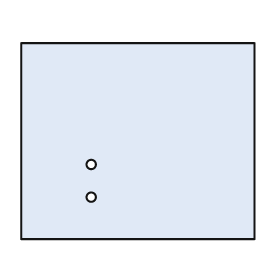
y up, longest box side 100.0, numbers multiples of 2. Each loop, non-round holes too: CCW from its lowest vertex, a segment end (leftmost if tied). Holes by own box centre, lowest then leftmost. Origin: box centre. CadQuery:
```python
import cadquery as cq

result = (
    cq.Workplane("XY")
    .moveTo(-50.0, -42.0)
    .lineTo(50.0, -42.0)
    .lineTo(50.0, 42.0)
    .lineTo(-50.0, 42.0)
    .close()
    .moveTo(-20.0, -24.0)
    .circle(2.0)
    .moveTo(-20.0, -10.0)
    .circle(2.0)
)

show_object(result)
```